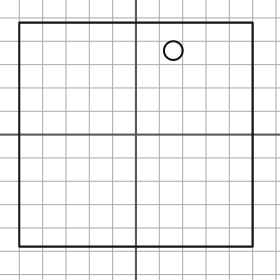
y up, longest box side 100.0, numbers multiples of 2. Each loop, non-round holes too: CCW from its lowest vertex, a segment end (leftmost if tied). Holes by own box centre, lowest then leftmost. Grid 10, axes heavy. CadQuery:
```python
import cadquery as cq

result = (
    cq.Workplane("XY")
    .moveTo(-50.0, -48.0)
    .lineTo(50.0, -48.0)
    .lineTo(50.0, 48.0)
    .lineTo(-50.0, 48.0)
    .close()
    .moveTo(16.0, 36.0)
    .circle(4.0)
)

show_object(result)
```